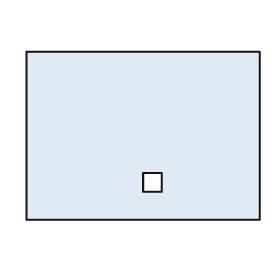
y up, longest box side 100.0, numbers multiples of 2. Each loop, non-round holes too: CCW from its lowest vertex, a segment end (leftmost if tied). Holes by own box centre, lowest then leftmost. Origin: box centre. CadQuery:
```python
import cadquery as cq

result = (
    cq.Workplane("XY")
    .moveTo(-50.0, -36.0)
    .lineTo(50.0, -36.0)
    .lineTo(50.0, 36.0)
    .lineTo(-50.0, 36.0)
    .close()
    .moveTo(0.0, -24.0)
    .lineTo(8.0, -24.0)
    .lineTo(8.0, -16.0)
    .lineTo(0.0, -16.0)
    .close()
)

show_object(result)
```